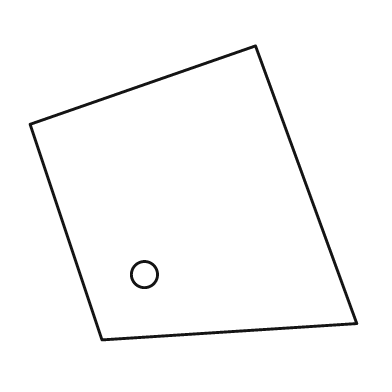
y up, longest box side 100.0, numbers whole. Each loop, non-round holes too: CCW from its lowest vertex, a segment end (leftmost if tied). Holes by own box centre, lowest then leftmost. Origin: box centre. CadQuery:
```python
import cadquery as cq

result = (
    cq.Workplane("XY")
    .moveTo(-28.0, -45.0)
    .lineTo(50.0, -40.0)
    .lineTo(19.0, 45.0)
    .lineTo(-50.0, 21.0)
    .close()
    .moveTo(-15.0, -25.0)
    .circle(4.0)
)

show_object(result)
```